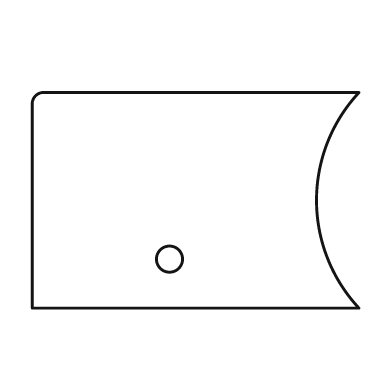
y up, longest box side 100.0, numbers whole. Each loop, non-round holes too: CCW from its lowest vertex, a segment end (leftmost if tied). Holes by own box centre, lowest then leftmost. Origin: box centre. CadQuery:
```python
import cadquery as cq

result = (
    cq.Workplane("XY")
    .moveTo(-50.0, -33.0)
    .lineTo(50.0, -33.0)
    .threePointArc((37.0, 0.0), (50.0, 33.0))
    .lineTo(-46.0, 33.0)
    .threePointArc((-49.0, 32.0), (-50.0, 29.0))
    .close()
    .moveTo(-8.0, -18.0)
    .circle(4.0)
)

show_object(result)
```